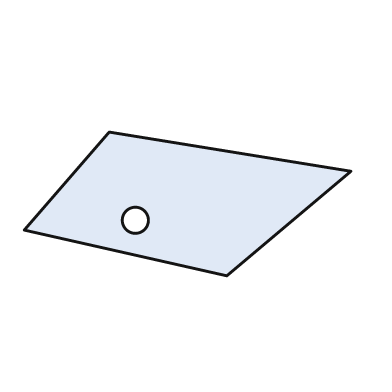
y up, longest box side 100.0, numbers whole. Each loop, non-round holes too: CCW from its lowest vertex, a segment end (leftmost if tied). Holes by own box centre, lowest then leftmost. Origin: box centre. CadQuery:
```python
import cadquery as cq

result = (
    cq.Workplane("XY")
    .moveTo(12.0, -22.0)
    .lineTo(50.0, 10.0)
    .lineTo(-24.0, 22.0)
    .lineTo(-50.0, -8.0)
    .close()
    .moveTo(-16.0, -5.0)
    .circle(4.0)
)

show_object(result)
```